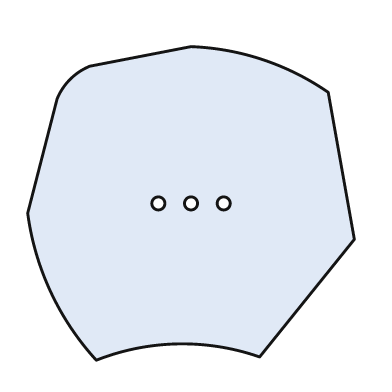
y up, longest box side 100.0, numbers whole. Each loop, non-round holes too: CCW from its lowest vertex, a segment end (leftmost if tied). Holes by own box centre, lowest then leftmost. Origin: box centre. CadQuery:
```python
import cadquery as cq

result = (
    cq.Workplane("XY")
    .moveTo(-29.0, -48.0)
    .threePointArc((-4.0, -43.0), (21.0, -47.0))
    .lineTo(50.0, -11.0)
    .lineTo(42.0, 34.0)
    .threePointArc((22.0, 44.0), (0.0, 48.0))
    .lineTo(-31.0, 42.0)
    .threePointArc((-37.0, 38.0), (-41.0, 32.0))
    .lineTo(-50.0, -3.0)
    .threePointArc((-43.0, -27.0), (-29.0, -48.0))
    .close()
    .moveTo(-10.0, 0.0)
    .circle(2.0)
    .moveTo(0.0, 0.0)
    .circle(2.0)
    .moveTo(10.0, 0.0)
    .circle(2.0)
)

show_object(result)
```